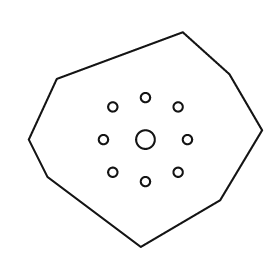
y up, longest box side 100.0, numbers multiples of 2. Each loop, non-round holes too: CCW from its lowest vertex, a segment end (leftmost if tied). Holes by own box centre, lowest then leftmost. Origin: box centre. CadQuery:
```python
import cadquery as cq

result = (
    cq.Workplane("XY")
    .moveTo(-2.0, -46.0)
    .lineTo(32.0, -26.0)
    .lineTo(50.0, 4.0)
    .lineTo(36.0, 28.0)
    .lineTo(16.0, 46.0)
    .lineTo(-38.0, 26.0)
    .lineTo(-50.0, 0.0)
    .lineTo(-42.0, -16.0)
    .close()
    .moveTo(0.0, -18.0)
    .circle(2.0)
    .moveTo(-14.0, -14.0)
    .circle(2.0)
    .moveTo(14.0, -14.0)
    .circle(2.0)
    .moveTo(-18.0, 0.0)
    .circle(2.0)
    .moveTo(0.0, 0.0)
    .circle(4.0)
    .moveTo(18.0, 0.0)
    .circle(2.0)
    .moveTo(-14.0, 14.0)
    .circle(2.0)
    .moveTo(14.0, 14.0)
    .circle(2.0)
    .moveTo(0.0, 18.0)
    .circle(2.0)
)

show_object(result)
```